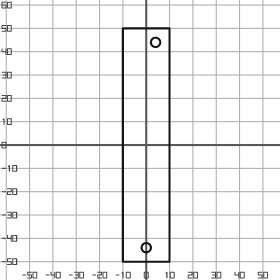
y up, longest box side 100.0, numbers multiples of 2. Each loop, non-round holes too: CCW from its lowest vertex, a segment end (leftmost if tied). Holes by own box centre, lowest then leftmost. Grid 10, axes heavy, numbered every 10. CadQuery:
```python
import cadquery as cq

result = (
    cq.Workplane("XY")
    .moveTo(-10.0, -50.0)
    .lineTo(10.0, -50.0)
    .lineTo(10.0, 50.0)
    .lineTo(-10.0, 50.0)
    .close()
    .moveTo(0.0, -44.0)
    .circle(2.0)
    .moveTo(4.0, 44.0)
    .circle(2.0)
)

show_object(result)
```